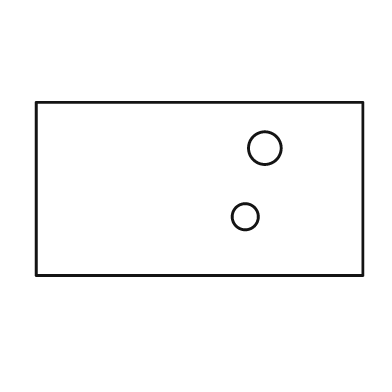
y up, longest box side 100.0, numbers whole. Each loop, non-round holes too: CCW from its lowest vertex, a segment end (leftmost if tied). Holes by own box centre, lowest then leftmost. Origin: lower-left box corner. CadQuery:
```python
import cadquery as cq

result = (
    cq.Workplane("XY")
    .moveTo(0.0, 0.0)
    .lineTo(100.0, 0.0)
    .lineTo(100.0, 53.0)
    .lineTo(0.0, 53.0)
    .close()
    .moveTo(64.0, 18.0)
    .circle(4.0)
    .moveTo(70.0, 39.0)
    .circle(5.0)
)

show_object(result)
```